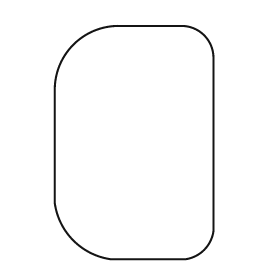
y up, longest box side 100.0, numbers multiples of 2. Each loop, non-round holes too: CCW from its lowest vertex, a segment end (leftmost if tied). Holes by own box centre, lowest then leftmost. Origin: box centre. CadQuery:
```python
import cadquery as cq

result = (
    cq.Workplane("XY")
    .moveTo(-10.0, -50.0)
    .lineTo(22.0, -50.0)
    .threePointArc((30.0, -46.0), (34.0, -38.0))
    .lineTo(34.0, 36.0)
    .threePointArc((30.0, 46.0), (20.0, 50.0))
    .lineTo(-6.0, 50.0)
    .threePointArc((-26.0, 42.0), (-34.0, 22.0))
    .lineTo(-34.0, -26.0)
    .threePointArc((-26.0, -42.0), (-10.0, -50.0))
    .close()
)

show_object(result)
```